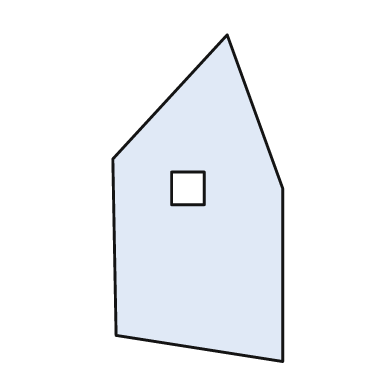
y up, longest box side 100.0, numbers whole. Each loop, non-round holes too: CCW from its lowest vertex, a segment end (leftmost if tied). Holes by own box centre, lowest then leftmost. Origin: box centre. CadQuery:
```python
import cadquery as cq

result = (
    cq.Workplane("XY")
    .moveTo(26.0, -50.0)
    .lineTo(26.0, 3.0)
    .lineTo(9.0, 50.0)
    .lineTo(-26.0, 12.0)
    .lineTo(-25.0, -42.0)
    .close()
    .moveTo(-8.0, -2.0)
    .lineTo(2.0, -2.0)
    .lineTo(2.0, 8.0)
    .lineTo(-8.0, 8.0)
    .close()
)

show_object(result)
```